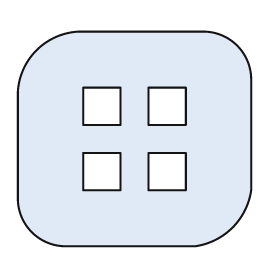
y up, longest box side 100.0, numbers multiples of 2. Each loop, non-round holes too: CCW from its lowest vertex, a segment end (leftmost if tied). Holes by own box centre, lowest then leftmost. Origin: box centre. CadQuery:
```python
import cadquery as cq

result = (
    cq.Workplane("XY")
    .moveTo(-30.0, -46.0)
    .lineTo(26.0, -46.0)
    .threePointArc((42.0, -38.0), (50.0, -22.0))
    .lineTo(50.0, 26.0)
    .threePointArc((44.0, 40.0), (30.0, 46.0))
    .lineTo(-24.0, 46.0)
    .threePointArc((-42.0, 38.0), (-50.0, 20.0))
    .lineTo(-50.0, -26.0)
    .threePointArc((-44.0, -40.0), (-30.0, -46.0))
    .close()
    .moveTo(-22.0, -22.0)
    .lineTo(-6.0, -22.0)
    .lineTo(-6.0, -6.0)
    .lineTo(-22.0, -6.0)
    .close()
    .moveTo(6.0, -22.0)
    .lineTo(22.0, -22.0)
    .lineTo(22.0, -6.0)
    .lineTo(6.0, -6.0)
    .close()
    .moveTo(-22.0, 6.0)
    .lineTo(-6.0, 6.0)
    .lineTo(-6.0, 22.0)
    .lineTo(-22.0, 22.0)
    .close()
    .moveTo(6.0, 6.0)
    .lineTo(22.0, 6.0)
    .lineTo(22.0, 22.0)
    .lineTo(6.0, 22.0)
    .close()
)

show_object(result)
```